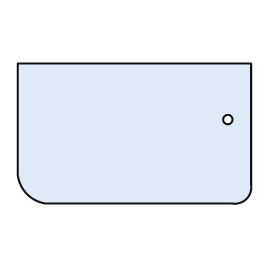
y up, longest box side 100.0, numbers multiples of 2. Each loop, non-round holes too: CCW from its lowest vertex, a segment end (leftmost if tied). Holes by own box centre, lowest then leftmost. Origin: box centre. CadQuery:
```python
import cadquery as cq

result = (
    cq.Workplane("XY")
    .moveTo(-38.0, -30.0)
    .lineTo(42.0, -30.0)
    .threePointArc((48.0, -28.0), (50.0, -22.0))
    .lineTo(50.0, 30.0)
    .lineTo(-50.0, 30.0)
    .lineTo(-50.0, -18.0)
    .threePointArc((-46.0, -26.0), (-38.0, -30.0))
    .close()
    .moveTo(40.0, 6.0)
    .circle(2.0)
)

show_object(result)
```